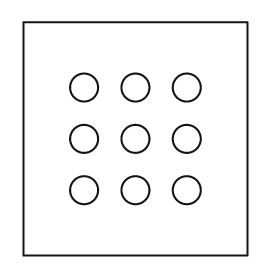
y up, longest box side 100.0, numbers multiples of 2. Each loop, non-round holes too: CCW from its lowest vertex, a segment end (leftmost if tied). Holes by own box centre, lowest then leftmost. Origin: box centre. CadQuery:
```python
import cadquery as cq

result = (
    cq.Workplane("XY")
    .moveTo(-48.0, -50.0)
    .lineTo(48.0, -50.0)
    .lineTo(48.0, 50.0)
    .lineTo(-48.0, 50.0)
    .close()
    .moveTo(-22.0, -22.0)
    .circle(6.0)
    .moveTo(0.0, -22.0)
    .circle(6.0)
    .moveTo(22.0, -22.0)
    .circle(6.0)
    .moveTo(-22.0, 0.0)
    .circle(6.0)
    .moveTo(0.0, 0.0)
    .circle(6.0)
    .moveTo(22.0, 0.0)
    .circle(6.0)
    .moveTo(-22.0, 22.0)
    .circle(6.0)
    .moveTo(0.0, 22.0)
    .circle(6.0)
    .moveTo(22.0, 22.0)
    .circle(6.0)
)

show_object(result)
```